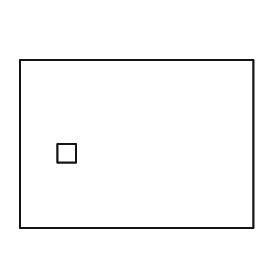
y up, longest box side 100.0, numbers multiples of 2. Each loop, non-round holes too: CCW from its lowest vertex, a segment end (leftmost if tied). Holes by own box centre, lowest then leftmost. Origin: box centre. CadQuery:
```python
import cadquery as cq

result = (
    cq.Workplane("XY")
    .moveTo(-50.0, -36.0)
    .lineTo(50.0, -36.0)
    .lineTo(50.0, 36.0)
    .lineTo(-50.0, 36.0)
    .close()
    .moveTo(-34.0, -8.0)
    .lineTo(-26.0, -8.0)
    .lineTo(-26.0, 0.0)
    .lineTo(-34.0, 0.0)
    .close()
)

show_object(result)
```